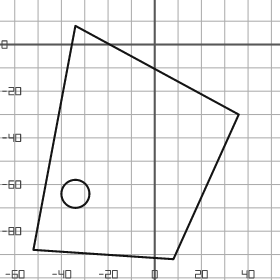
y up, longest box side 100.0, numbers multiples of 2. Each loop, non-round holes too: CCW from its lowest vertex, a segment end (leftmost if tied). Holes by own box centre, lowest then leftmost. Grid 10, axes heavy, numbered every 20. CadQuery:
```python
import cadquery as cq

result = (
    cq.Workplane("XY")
    .moveTo(8.0, -92.0)
    .lineTo(36.0, -30.0)
    .lineTo(-34.0, 8.0)
    .lineTo(-52.0, -88.0)
    .close()
    .moveTo(-34.0, -64.0)
    .circle(6.0)
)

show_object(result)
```